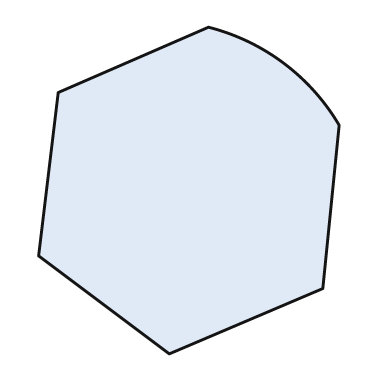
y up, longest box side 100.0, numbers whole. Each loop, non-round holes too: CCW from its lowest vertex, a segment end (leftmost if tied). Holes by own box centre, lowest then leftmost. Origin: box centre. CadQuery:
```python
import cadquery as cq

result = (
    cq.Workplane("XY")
    .moveTo(-6.0, -50.0)
    .lineTo(41.0, -30.0)
    .lineTo(46.0, 20.0)
    .threePointArc((29.0, 39.0), (6.0, 50.0))
    .lineTo(-40.0, 30.0)
    .lineTo(-46.0, -20.0)
    .close()
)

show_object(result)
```